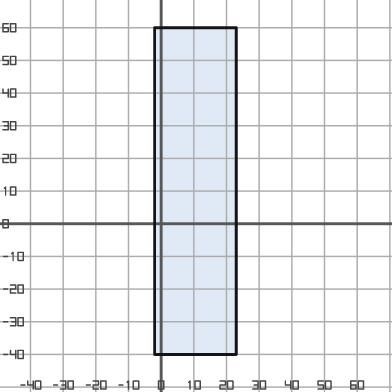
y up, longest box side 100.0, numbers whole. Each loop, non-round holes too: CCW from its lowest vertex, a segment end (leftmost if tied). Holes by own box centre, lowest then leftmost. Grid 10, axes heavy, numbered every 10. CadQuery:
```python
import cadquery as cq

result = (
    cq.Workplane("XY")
    .moveTo(-2.0, -40.0)
    .lineTo(23.0, -40.0)
    .lineTo(23.0, 60.0)
    .lineTo(-2.0, 60.0)
    .close()
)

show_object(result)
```